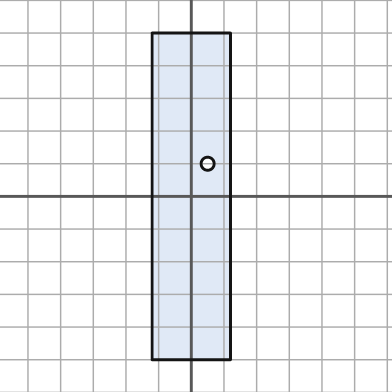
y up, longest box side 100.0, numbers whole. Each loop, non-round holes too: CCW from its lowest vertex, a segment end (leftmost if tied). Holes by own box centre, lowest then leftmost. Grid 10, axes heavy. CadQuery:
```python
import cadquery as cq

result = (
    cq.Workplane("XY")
    .moveTo(-12.0, -50.0)
    .lineTo(12.0, -50.0)
    .lineTo(12.0, 50.0)
    .lineTo(-12.0, 50.0)
    .close()
    .moveTo(5.0, 10.0)
    .circle(2.0)
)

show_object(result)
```